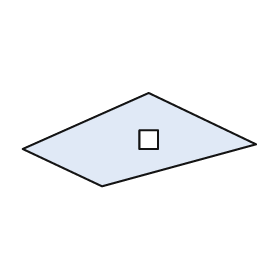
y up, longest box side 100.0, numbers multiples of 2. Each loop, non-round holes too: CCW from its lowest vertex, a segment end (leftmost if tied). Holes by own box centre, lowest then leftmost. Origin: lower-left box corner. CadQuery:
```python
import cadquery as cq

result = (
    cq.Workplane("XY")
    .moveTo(34.0, 0.0)
    .lineTo(100.0, 18.0)
    .lineTo(54.0, 40.0)
    .lineTo(0.0, 16.0)
    .close()
    .moveTo(50.0, 16.0)
    .lineTo(58.0, 16.0)
    .lineTo(58.0, 24.0)
    .lineTo(50.0, 24.0)
    .close()
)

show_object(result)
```